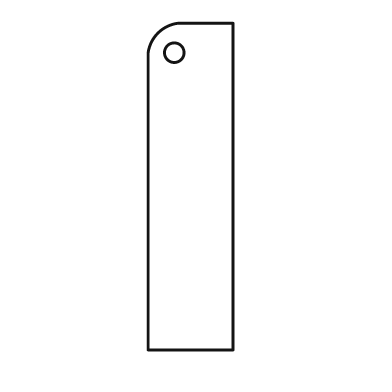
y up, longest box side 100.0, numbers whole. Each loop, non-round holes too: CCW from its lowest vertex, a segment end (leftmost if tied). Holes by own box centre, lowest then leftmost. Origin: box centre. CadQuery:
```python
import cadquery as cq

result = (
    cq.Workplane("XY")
    .moveTo(-13.0, -50.0)
    .lineTo(13.0, -50.0)
    .lineTo(13.0, 50.0)
    .lineTo(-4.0, 50.0)
    .threePointArc((-10.0, 47.0), (-13.0, 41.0))
    .close()
    .moveTo(-5.0, 41.0)
    .circle(3.0)
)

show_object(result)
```